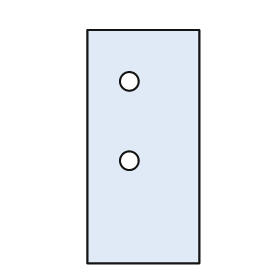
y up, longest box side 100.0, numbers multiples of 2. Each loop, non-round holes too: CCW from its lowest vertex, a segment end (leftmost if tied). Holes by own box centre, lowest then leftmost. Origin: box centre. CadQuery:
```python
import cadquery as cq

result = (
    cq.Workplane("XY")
    .moveTo(-24.0, -50.0)
    .lineTo(24.0, -50.0)
    .lineTo(24.0, 50.0)
    .lineTo(-24.0, 50.0)
    .close()
    .moveTo(-6.0, -6.0)
    .circle(4.0)
    .moveTo(-6.0, 28.0)
    .circle(4.0)
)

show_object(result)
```